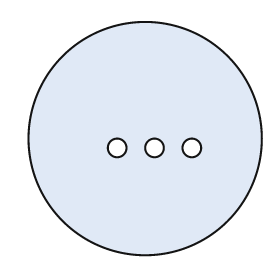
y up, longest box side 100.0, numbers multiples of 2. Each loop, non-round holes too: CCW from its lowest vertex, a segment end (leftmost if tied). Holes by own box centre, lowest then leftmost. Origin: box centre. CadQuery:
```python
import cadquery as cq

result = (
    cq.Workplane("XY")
    .moveTo(0.0, 0.0)
    .circle(50.0)
    .moveTo(-12.0, -4.0)
    .circle(4.0)
    .moveTo(4.0, -4.0)
    .circle(4.0)
    .moveTo(20.0, -4.0)
    .circle(4.0)
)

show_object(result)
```